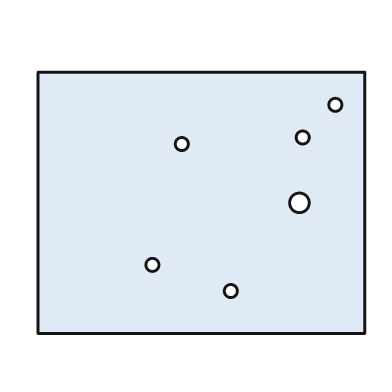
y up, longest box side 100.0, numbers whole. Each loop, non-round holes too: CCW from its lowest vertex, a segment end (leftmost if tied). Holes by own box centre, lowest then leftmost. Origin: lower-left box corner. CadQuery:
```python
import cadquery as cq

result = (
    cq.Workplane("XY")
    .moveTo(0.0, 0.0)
    .lineTo(100.0, 0.0)
    .lineTo(100.0, 80.0)
    .lineTo(0.0, 80.0)
    .close()
    .moveTo(59.0, 13.0)
    .circle(2.0)
    .moveTo(35.0, 21.0)
    .circle(2.0)
    .moveTo(80.0, 40.0)
    .circle(3.0)
    .moveTo(44.0, 58.0)
    .circle(2.0)
    .moveTo(81.0, 60.0)
    .circle(2.0)
    .moveTo(91.0, 70.0)
    .circle(2.0)
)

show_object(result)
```